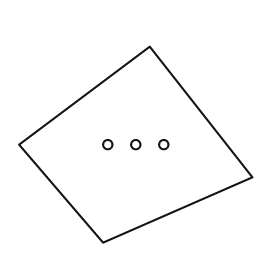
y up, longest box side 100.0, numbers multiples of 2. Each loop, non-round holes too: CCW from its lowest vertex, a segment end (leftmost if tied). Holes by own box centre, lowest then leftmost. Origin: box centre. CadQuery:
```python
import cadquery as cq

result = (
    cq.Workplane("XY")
    .moveTo(-14.0, -42.0)
    .lineTo(50.0, -14.0)
    .lineTo(6.0, 42.0)
    .lineTo(-50.0, 0.0)
    .close()
    .moveTo(-12.0, 0.0)
    .circle(2.0)
    .moveTo(0.0, 0.0)
    .circle(2.0)
    .moveTo(12.0, 0.0)
    .circle(2.0)
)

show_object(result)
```